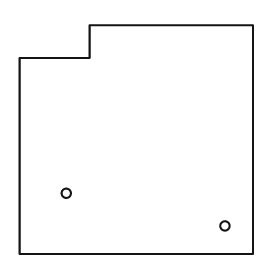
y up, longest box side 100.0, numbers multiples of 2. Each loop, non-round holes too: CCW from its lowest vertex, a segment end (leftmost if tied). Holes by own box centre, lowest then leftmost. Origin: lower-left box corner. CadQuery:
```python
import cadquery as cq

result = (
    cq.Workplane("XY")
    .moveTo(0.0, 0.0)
    .lineTo(100.0, 0.0)
    .lineTo(100.0, 98.0)
    .lineTo(30.0, 98.0)
    .lineTo(30.0, 84.0)
    .lineTo(0.0, 84.0)
    .close()
    .moveTo(88.0, 12.0)
    .circle(2.0)
    .moveTo(20.0, 26.0)
    .circle(2.0)
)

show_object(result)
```